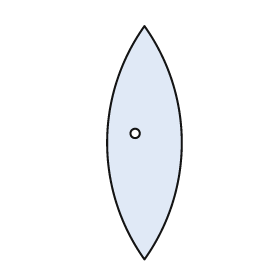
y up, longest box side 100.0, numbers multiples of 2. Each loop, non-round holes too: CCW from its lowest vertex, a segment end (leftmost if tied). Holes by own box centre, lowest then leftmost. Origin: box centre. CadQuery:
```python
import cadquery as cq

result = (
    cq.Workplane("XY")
    .moveTo(0.0, -50.0)
    .threePointArc((16.0, 0.0), (0.0, 50.0))
    .threePointArc((-16.0, 0.0), (0.0, -50.0))
    .close()
    .moveTo(-4.0, 4.0)
    .circle(2.0)
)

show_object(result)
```